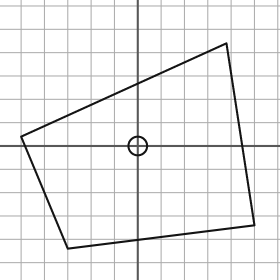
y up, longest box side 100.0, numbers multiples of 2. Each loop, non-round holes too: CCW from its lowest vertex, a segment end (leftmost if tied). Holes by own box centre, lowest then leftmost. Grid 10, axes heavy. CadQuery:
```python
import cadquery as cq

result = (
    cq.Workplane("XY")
    .moveTo(-30.0, -44.0)
    .lineTo(50.0, -34.0)
    .lineTo(38.0, 44.0)
    .lineTo(-50.0, 4.0)
    .close()
    .moveTo(0.0, 0.0)
    .circle(4.0)
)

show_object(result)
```